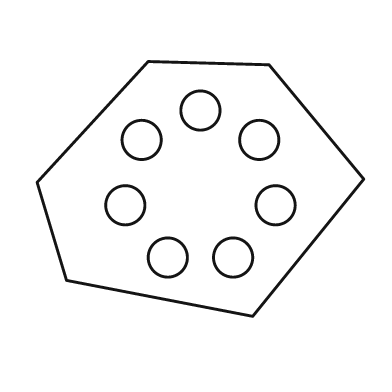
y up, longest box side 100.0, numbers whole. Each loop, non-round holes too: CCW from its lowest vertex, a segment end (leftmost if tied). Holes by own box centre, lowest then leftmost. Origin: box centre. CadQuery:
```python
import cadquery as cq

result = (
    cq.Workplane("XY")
    .moveTo(16.0, -39.0)
    .lineTo(50.0, 3.0)
    .lineTo(21.0, 38.0)
    .lineTo(-16.0, 39.0)
    .lineTo(-50.0, 2.0)
    .lineTo(-41.0, -28.0)
    .close()
    .moveTo(-10.0, -21.0)
    .circle(6.0)
    .moveTo(10.0, -21.0)
    .circle(6.0)
    .moveTo(-23.0, -5.0)
    .circle(6.0)
    .moveTo(23.0, -5.0)
    .circle(6.0)
    .moveTo(-18.0, 15.0)
    .circle(6.0)
    .moveTo(18.0, 15.0)
    .circle(6.0)
    .moveTo(0.0, 24.0)
    .circle(6.0)
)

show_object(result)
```